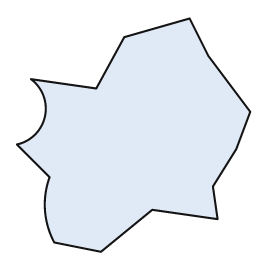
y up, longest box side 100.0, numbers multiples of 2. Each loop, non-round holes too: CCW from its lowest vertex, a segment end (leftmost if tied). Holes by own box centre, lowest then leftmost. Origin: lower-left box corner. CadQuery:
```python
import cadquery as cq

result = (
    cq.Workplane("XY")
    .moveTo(36.0, 0.0)
    .lineTo(58.0, 18.0)
    .lineTo(86.0, 14.0)
    .lineTo(84.0, 28.0)
    .lineTo(94.0, 44.0)
    .lineTo(100.0, 60.0)
    .lineTo(82.0, 84.0)
    .lineTo(74.0, 100.0)
    .lineTo(46.0, 92.0)
    .lineTo(34.0, 70.0)
    .lineTo(6.0, 74.0)
    .threePointArc((12.0, 58.0), (0.0, 46.0))
    .lineTo(14.0, 32.0)
    .threePointArc((12.0, 18.0), (16.0, 4.0))
    .close()
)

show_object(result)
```